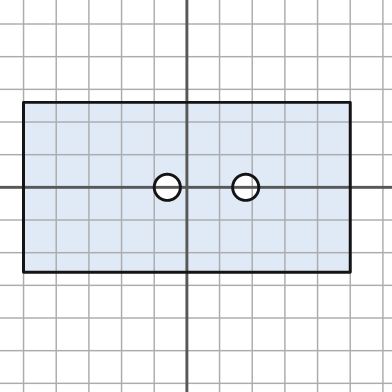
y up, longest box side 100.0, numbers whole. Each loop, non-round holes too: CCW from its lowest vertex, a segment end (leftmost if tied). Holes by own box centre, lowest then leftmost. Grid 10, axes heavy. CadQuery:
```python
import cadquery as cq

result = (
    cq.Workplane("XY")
    .moveTo(-50.0, -26.0)
    .lineTo(50.0, -26.0)
    .lineTo(50.0, 26.0)
    .lineTo(-50.0, 26.0)
    .close()
    .moveTo(-6.0, 0.0)
    .circle(4.0)
    .moveTo(18.0, 0.0)
    .circle(4.0)
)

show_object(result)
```